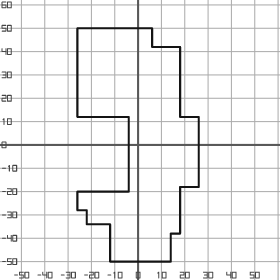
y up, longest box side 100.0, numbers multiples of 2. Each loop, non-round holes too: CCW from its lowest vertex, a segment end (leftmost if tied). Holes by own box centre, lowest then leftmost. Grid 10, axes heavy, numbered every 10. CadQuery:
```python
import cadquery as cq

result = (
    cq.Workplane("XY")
    .moveTo(-12.0, -50.0)
    .lineTo(14.0, -50.0)
    .lineTo(14.0, -38.0)
    .lineTo(18.0, -38.0)
    .lineTo(18.0, -18.0)
    .lineTo(26.0, -18.0)
    .lineTo(26.0, 12.0)
    .lineTo(18.0, 12.0)
    .lineTo(18.0, 42.0)
    .lineTo(6.0, 42.0)
    .lineTo(6.0, 50.0)
    .lineTo(-26.0, 50.0)
    .lineTo(-26.0, 12.0)
    .lineTo(-4.0, 12.0)
    .lineTo(-4.0, -20.0)
    .lineTo(-26.0, -20.0)
    .lineTo(-26.0, -28.0)
    .lineTo(-22.0, -28.0)
    .lineTo(-22.0, -34.0)
    .lineTo(-12.0, -34.0)
    .close()
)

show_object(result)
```